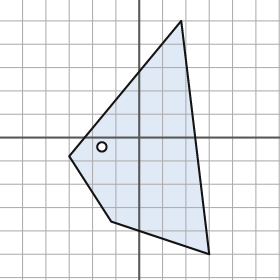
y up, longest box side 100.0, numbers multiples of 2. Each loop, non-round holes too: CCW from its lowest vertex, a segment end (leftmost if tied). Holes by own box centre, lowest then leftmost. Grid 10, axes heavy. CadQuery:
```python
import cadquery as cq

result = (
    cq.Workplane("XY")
    .moveTo(30.0, -50.0)
    .lineTo(18.0, 50.0)
    .lineTo(-30.0, -8.0)
    .lineTo(-12.0, -36.0)
    .close()
    .moveTo(-16.0, -4.0)
    .circle(2.0)
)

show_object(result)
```